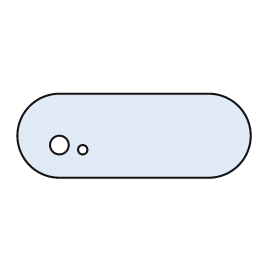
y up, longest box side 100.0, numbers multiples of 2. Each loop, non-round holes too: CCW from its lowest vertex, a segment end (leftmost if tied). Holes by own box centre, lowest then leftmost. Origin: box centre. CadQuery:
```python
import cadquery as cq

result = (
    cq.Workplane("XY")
    .moveTo(-32.0, -18.0)
    .lineTo(32.0, -18.0)
    .threePointArc((50.0, 0.0), (32.0, 18.0))
    .lineTo(-32.0, 18.0)
    .threePointArc((-50.0, 0.0), (-32.0, -18.0))
    .close()
    .moveTo(-22.0, -6.0)
    .circle(2.0)
    .moveTo(-32.0, -4.0)
    .circle(4.0)
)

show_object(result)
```